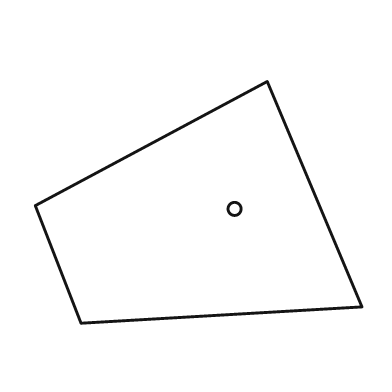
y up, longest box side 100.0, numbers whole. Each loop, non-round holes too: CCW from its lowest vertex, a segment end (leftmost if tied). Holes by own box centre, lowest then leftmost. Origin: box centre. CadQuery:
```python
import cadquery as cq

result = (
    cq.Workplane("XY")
    .moveTo(-36.0, -37.0)
    .lineTo(50.0, -32.0)
    .lineTo(21.0, 37.0)
    .lineTo(-50.0, -1.0)
    .close()
    .moveTo(11.0, -2.0)
    .circle(2.0)
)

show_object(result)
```